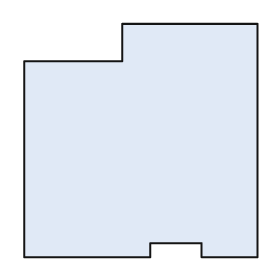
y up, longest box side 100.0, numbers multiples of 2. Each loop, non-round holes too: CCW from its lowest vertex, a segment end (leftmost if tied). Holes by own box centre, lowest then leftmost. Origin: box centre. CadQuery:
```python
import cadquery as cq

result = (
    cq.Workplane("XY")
    .moveTo(-50.0, -50.0)
    .lineTo(4.0, -50.0)
    .lineTo(4.0, -44.0)
    .lineTo(26.0, -44.0)
    .lineTo(26.0, -50.0)
    .lineTo(50.0, -50.0)
    .lineTo(50.0, 50.0)
    .lineTo(-8.0, 50.0)
    .lineTo(-8.0, 34.0)
    .lineTo(-50.0, 34.0)
    .close()
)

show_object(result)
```